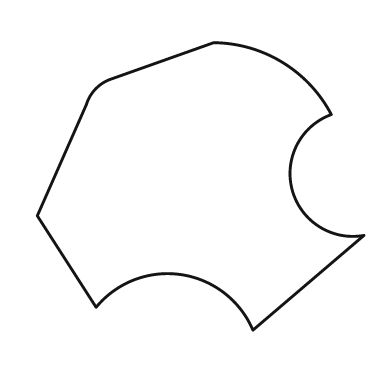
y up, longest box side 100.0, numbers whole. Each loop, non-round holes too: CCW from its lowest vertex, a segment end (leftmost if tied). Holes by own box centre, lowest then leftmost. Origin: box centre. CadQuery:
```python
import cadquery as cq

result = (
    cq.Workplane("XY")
    .moveTo(16.0, -44.0)
    .lineTo(50.0, -15.0)
    .threePointArc((28.0, -1.0), (40.0, 22.0))
    .threePointArc((25.0, 38.0), (4.0, 44.0))
    .lineTo(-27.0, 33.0)
    .threePointArc((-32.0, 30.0), (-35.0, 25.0))
    .lineTo(-50.0, -9.0)
    .lineTo(-32.0, -37.0)
    .threePointArc((-6.0, -27.0), (16.0, -44.0))
    .close()
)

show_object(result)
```